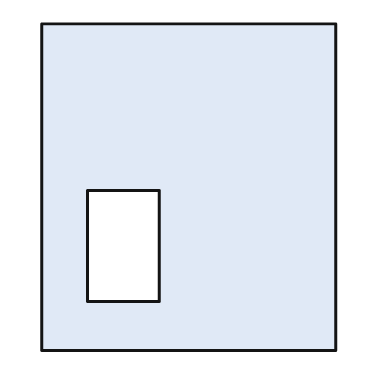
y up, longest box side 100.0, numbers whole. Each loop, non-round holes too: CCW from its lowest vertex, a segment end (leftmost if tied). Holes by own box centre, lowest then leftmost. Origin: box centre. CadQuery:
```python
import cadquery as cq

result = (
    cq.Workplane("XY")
    .moveTo(-45.0, -50.0)
    .lineTo(45.0, -50.0)
    .lineTo(45.0, 50.0)
    .lineTo(-45.0, 50.0)
    .close()
    .moveTo(-31.0, -35.0)
    .lineTo(-9.0, -35.0)
    .lineTo(-9.0, -1.0)
    .lineTo(-31.0, -1.0)
    .close()
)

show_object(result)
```